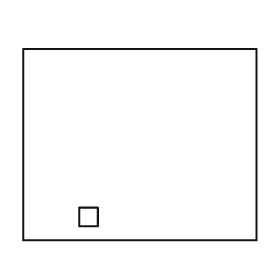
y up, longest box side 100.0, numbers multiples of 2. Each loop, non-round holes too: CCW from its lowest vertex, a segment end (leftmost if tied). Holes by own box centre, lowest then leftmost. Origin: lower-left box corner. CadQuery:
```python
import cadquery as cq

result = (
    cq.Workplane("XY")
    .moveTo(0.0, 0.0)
    .lineTo(100.0, 0.0)
    .lineTo(100.0, 82.0)
    .lineTo(0.0, 82.0)
    .close()
    .moveTo(24.0, 6.0)
    .lineTo(32.0, 6.0)
    .lineTo(32.0, 14.0)
    .lineTo(24.0, 14.0)
    .close()
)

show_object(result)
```